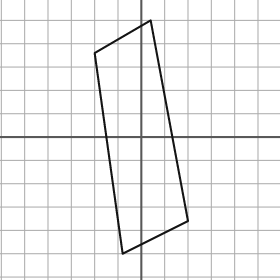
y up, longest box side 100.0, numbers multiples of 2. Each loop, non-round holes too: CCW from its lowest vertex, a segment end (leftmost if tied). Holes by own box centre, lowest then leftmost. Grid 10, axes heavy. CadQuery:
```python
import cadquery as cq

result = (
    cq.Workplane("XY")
    .moveTo(-8.0, -50.0)
    .lineTo(20.0, -36.0)
    .lineTo(4.0, 50.0)
    .lineTo(-20.0, 36.0)
    .close()
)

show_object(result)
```